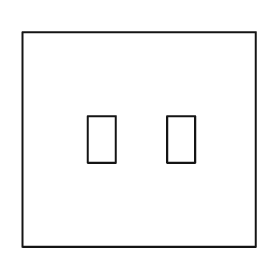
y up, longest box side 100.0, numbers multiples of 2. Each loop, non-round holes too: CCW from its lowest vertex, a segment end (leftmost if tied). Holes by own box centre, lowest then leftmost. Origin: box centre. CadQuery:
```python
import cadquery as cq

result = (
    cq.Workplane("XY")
    .moveTo(-50.0, -46.0)
    .lineTo(50.0, -46.0)
    .lineTo(50.0, 46.0)
    .lineTo(-50.0, 46.0)
    .close()
    .moveTo(-22.0, -10.0)
    .lineTo(-10.0, -10.0)
    .lineTo(-10.0, 10.0)
    .lineTo(-22.0, 10.0)
    .close()
    .moveTo(12.0, -10.0)
    .lineTo(24.0, -10.0)
    .lineTo(24.0, 10.0)
    .lineTo(12.0, 10.0)
    .close()
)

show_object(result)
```